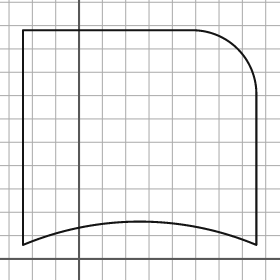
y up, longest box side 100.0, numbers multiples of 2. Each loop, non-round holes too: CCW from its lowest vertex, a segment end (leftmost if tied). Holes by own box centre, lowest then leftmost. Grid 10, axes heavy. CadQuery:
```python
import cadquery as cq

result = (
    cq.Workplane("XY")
    .moveTo(-24.0, 6.0)
    .threePointArc((26.0, 16.0), (76.0, 6.0))
    .lineTo(76.0, 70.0)
    .threePointArc((68.0, 90.0), (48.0, 98.0))
    .lineTo(-24.0, 98.0)
    .close()
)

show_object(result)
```